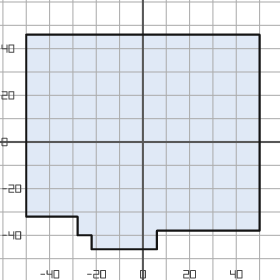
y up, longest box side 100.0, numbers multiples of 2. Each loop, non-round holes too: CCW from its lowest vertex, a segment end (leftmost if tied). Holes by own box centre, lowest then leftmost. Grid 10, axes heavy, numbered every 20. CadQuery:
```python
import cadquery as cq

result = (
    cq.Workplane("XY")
    .moveTo(-22.0, -46.0)
    .lineTo(6.0, -46.0)
    .lineTo(6.0, -38.0)
    .lineTo(50.0, -38.0)
    .lineTo(50.0, 46.0)
    .lineTo(-50.0, 46.0)
    .lineTo(-50.0, -32.0)
    .lineTo(-28.0, -32.0)
    .lineTo(-28.0, -40.0)
    .lineTo(-22.0, -40.0)
    .close()
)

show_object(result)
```